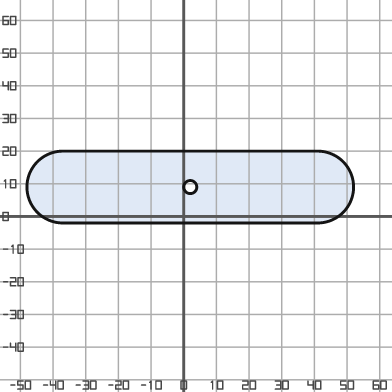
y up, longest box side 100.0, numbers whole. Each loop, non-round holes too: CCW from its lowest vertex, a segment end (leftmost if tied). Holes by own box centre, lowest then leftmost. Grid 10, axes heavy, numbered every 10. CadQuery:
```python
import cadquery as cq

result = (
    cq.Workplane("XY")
    .moveTo(-37.0, -2.0)
    .lineTo(41.0, -2.0)
    .threePointArc((52.0, 9.0), (41.0, 20.0))
    .lineTo(-37.0, 20.0)
    .threePointArc((-48.0, 9.0), (-37.0, -2.0))
    .close()
    .moveTo(2.0, 9.0)
    .circle(2.0)
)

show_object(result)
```